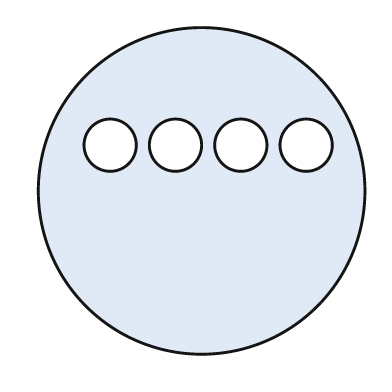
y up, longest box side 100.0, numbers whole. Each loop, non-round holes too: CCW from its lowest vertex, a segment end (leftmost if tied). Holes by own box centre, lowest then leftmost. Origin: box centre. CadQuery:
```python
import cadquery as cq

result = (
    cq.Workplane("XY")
    .moveTo(0.0, 0.0)
    .circle(50.0)
    .moveTo(-28.0, 14.0)
    .circle(8.0)
    .moveTo(-8.0, 14.0)
    .circle(8.0)
    .moveTo(12.0, 14.0)
    .circle(8.0)
    .moveTo(32.0, 14.0)
    .circle(8.0)
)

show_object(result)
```